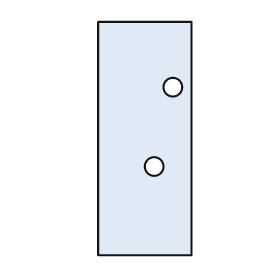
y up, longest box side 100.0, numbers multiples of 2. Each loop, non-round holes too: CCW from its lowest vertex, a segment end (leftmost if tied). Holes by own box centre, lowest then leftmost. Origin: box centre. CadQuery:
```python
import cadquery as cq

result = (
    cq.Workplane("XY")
    .moveTo(-20.0, -50.0)
    .lineTo(20.0, -50.0)
    .lineTo(20.0, 50.0)
    .lineTo(-20.0, 50.0)
    .close()
    .moveTo(4.0, -12.0)
    .circle(4.0)
    .moveTo(12.0, 22.0)
    .circle(4.0)
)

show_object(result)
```